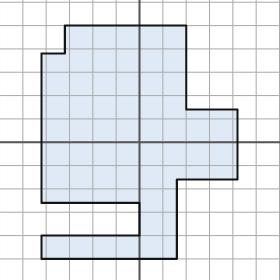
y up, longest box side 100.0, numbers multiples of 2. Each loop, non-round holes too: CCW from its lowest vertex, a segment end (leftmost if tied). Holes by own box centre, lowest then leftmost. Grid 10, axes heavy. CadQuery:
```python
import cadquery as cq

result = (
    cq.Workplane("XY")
    .moveTo(-42.0, -50.0)
    .lineTo(16.0, -50.0)
    .lineTo(16.0, -16.0)
    .lineTo(42.0, -16.0)
    .lineTo(42.0, 14.0)
    .lineTo(20.0, 14.0)
    .lineTo(20.0, 50.0)
    .lineTo(-32.0, 50.0)
    .lineTo(-32.0, 38.0)
    .lineTo(-42.0, 38.0)
    .lineTo(-42.0, -26.0)
    .lineTo(0.0, -26.0)
    .lineTo(0.0, -40.0)
    .lineTo(-42.0, -40.0)
    .close()
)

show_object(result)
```